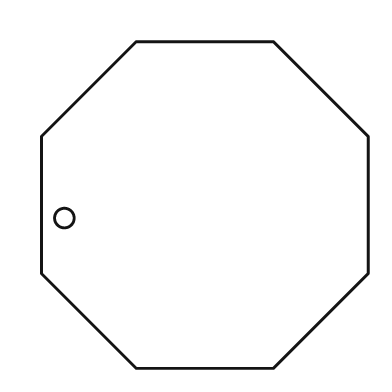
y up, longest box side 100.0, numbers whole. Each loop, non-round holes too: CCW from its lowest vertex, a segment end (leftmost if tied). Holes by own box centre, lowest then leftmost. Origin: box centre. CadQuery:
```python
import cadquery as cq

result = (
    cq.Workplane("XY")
    .moveTo(-21.0, -50.0)
    .lineTo(21.0, -50.0)
    .lineTo(50.0, -21.0)
    .lineTo(50.0, 21.0)
    .lineTo(21.0, 50.0)
    .lineTo(-21.0, 50.0)
    .lineTo(-50.0, 21.0)
    .lineTo(-50.0, -21.0)
    .close()
    .moveTo(-43.0, -4.0)
    .circle(3.0)
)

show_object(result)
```